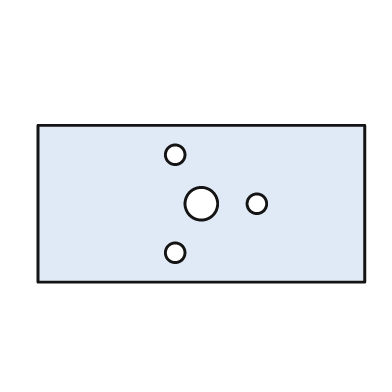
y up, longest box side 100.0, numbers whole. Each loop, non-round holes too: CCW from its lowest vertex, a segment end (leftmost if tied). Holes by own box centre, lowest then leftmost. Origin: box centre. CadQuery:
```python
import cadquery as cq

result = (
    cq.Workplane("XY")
    .moveTo(-50.0, -24.0)
    .lineTo(50.0, -24.0)
    .lineTo(50.0, 24.0)
    .lineTo(-50.0, 24.0)
    .close()
    .moveTo(-8.0, -15.0)
    .circle(3.0)
    .moveTo(0.0, 0.0)
    .circle(5.0)
    .moveTo(17.0, 0.0)
    .circle(3.0)
    .moveTo(-8.0, 15.0)
    .circle(3.0)
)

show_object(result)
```